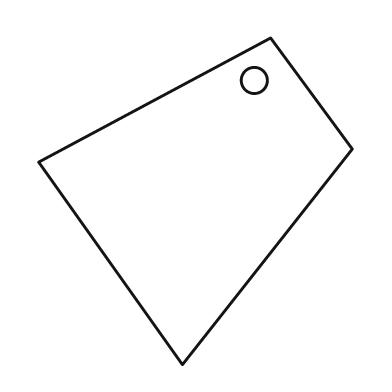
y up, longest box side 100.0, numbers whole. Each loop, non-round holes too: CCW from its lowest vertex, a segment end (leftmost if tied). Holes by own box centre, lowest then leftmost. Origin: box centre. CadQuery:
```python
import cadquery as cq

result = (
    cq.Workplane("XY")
    .moveTo(-4.0, -50.0)
    .lineTo(48.0, 16.0)
    .lineTo(23.0, 50.0)
    .lineTo(-48.0, 12.0)
    .close()
    .moveTo(18.0, 37.0)
    .circle(4.0)
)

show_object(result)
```